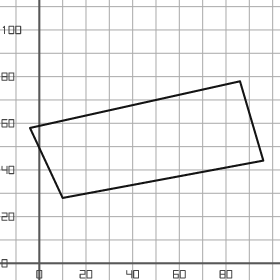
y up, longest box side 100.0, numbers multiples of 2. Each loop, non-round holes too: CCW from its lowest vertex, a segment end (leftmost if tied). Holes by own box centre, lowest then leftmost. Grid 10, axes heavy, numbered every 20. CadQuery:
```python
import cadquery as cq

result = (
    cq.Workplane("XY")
    .moveTo(10.0, 28.0)
    .lineTo(96.0, 44.0)
    .lineTo(86.0, 78.0)
    .lineTo(-4.0, 58.0)
    .close()
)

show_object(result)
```